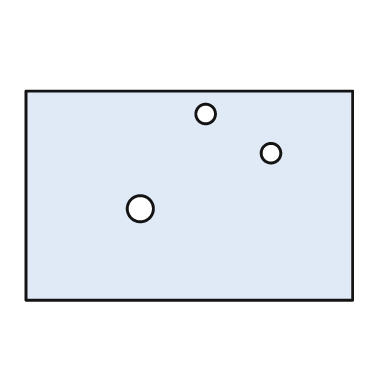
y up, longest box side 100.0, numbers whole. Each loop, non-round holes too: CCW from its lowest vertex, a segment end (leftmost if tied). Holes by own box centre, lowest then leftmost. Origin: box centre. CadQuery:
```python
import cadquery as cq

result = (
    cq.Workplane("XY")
    .moveTo(-50.0, -32.0)
    .lineTo(50.0, -32.0)
    .lineTo(50.0, 32.0)
    .lineTo(-50.0, 32.0)
    .close()
    .moveTo(-15.0, -4.0)
    .circle(4.0)
    .moveTo(25.0, 13.0)
    .circle(3.0)
    .moveTo(5.0, 25.0)
    .circle(3.0)
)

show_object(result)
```